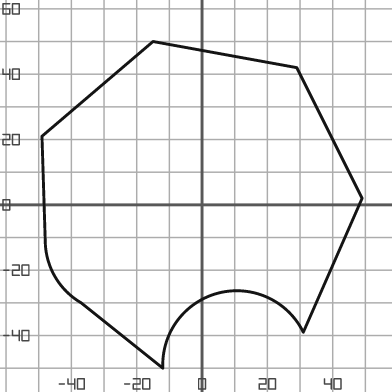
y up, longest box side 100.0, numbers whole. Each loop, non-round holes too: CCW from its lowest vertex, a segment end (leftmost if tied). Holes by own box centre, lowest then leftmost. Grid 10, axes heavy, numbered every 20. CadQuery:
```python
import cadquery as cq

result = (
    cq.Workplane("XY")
    .moveTo(-12.0, -50.0)
    .threePointArc((5.0, -27.0), (31.0, -39.0))
    .lineTo(49.0, 2.0)
    .lineTo(29.0, 42.0)
    .lineTo(-15.0, 50.0)
    .lineTo(-49.0, 21.0)
    .lineTo(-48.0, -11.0)
    .threePointArc((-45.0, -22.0), (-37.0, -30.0))
    .close()
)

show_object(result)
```